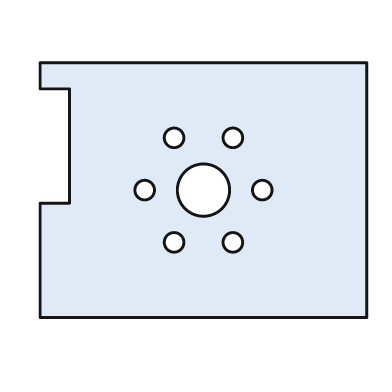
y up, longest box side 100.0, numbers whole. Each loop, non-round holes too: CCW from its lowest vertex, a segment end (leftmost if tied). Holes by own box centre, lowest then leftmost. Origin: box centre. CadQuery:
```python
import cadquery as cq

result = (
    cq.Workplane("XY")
    .moveTo(-50.0, -39.0)
    .lineTo(50.0, -39.0)
    .lineTo(50.0, 39.0)
    .lineTo(-50.0, 39.0)
    .lineTo(-50.0, 31.0)
    .lineTo(-41.0, 31.0)
    .lineTo(-41.0, -4.0)
    .lineTo(-50.0, -4.0)
    .close()
    .moveTo(-9.0, -16.0)
    .circle(3.0)
    .moveTo(9.0, -16.0)
    .circle(3.0)
    .moveTo(-18.0, 0.0)
    .circle(3.0)
    .moveTo(0.0, 0.0)
    .circle(8.0)
    .moveTo(18.0, 0.0)
    .circle(3.0)
    .moveTo(-9.0, 16.0)
    .circle(3.0)
    .moveTo(9.0, 16.0)
    .circle(3.0)
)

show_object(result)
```